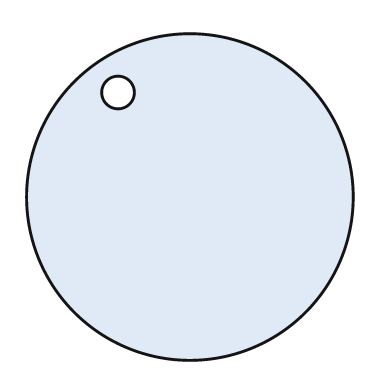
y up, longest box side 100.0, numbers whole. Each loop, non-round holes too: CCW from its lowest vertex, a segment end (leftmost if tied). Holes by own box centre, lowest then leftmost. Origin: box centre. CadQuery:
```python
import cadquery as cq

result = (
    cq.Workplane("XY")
    .moveTo(0.0, 0.0)
    .circle(50.0)
    .moveTo(-22.0, 32.0)
    .circle(5.0)
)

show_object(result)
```